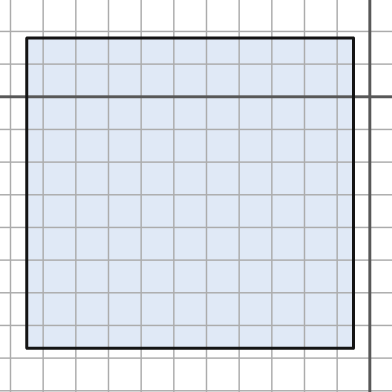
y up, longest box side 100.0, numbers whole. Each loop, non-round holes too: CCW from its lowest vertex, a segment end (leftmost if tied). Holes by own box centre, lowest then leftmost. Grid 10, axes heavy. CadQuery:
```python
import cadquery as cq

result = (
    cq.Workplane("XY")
    .moveTo(-105.0, -77.0)
    .lineTo(-5.0, -77.0)
    .lineTo(-5.0, 18.0)
    .lineTo(-105.0, 18.0)
    .close()
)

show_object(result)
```